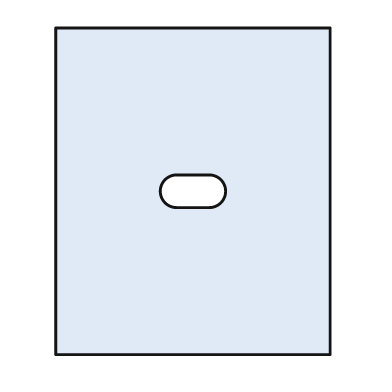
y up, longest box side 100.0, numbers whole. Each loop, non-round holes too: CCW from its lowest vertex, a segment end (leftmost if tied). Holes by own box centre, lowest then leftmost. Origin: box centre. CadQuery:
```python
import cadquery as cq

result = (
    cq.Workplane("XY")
    .moveTo(-42.0, -50.0)
    .lineTo(42.0, -50.0)
    .lineTo(42.0, 50.0)
    .lineTo(-42.0, 50.0)
    .close()
    .moveTo(-5.0, -5.0)
    .lineTo(5.0, -5.0)
    .threePointArc((10.0, 0.0), (5.0, 5.0))
    .lineTo(-5.0, 5.0)
    .threePointArc((-10.0, 0.0), (-5.0, -5.0))
    .close()
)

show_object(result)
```